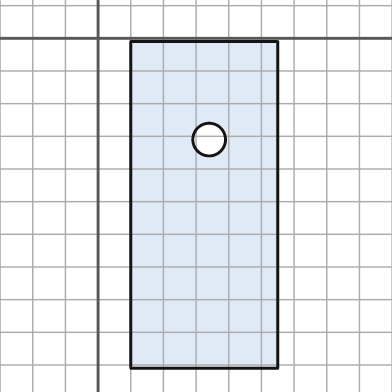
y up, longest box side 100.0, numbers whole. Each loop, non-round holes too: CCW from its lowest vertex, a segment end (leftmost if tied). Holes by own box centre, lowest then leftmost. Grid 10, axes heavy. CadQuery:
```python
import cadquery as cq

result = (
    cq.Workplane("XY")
    .moveTo(10.0, -101.0)
    .lineTo(55.0, -101.0)
    .lineTo(55.0, -1.0)
    .lineTo(10.0, -1.0)
    .close()
    .moveTo(34.0, -31.0)
    .circle(5.0)
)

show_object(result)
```